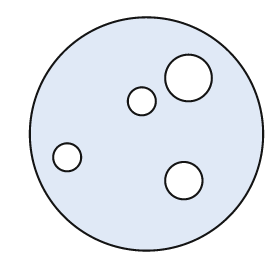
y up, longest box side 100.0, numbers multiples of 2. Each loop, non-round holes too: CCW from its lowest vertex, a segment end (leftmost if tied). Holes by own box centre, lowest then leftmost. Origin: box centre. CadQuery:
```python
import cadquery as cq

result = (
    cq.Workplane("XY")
    .moveTo(0.0, 0.0)
    .circle(50.0)
    .moveTo(16.0, -20.0)
    .circle(8.0)
    .moveTo(-34.0, -10.0)
    .circle(6.0)
    .moveTo(-2.0, 14.0)
    .circle(6.0)
    .moveTo(18.0, 24.0)
    .circle(10.0)
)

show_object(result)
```